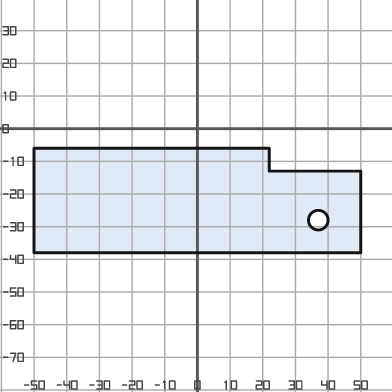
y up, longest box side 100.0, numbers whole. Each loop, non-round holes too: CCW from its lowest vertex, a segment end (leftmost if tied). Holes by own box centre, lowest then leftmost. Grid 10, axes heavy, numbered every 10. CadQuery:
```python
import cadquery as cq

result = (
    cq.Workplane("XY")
    .moveTo(-50.0, -38.0)
    .lineTo(50.0, -38.0)
    .lineTo(50.0, -13.0)
    .lineTo(22.0, -13.0)
    .lineTo(22.0, -6.0)
    .lineTo(-50.0, -6.0)
    .close()
    .moveTo(37.0, -28.0)
    .circle(3.0)
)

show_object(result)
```